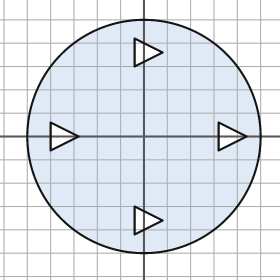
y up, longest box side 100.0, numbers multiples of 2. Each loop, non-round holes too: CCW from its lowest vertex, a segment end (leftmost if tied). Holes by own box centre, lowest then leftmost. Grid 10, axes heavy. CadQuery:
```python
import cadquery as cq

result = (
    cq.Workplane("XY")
    .moveTo(0.0, 0.0)
    .circle(50.0)
    .moveTo(-4.0, -42.0)
    .lineTo(8.0, -36.0)
    .lineTo(-4.0, -30.0)
    .close()
    .moveTo(-40.0, -6.0)
    .lineTo(-28.0, 0.0)
    .lineTo(-40.0, 6.0)
    .close()
    .moveTo(32.0, -6.0)
    .lineTo(44.0, 0.0)
    .lineTo(32.0, 6.0)
    .close()
    .moveTo(-4.0, 30.0)
    .lineTo(8.0, 36.0)
    .lineTo(-4.0, 42.0)
    .close()
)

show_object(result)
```